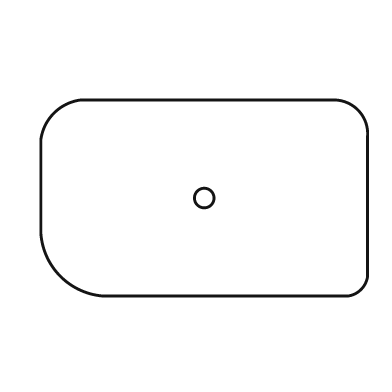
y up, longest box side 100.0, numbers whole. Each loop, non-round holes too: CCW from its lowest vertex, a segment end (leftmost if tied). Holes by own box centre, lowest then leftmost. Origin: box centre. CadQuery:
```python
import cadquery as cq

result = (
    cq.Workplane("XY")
    .moveTo(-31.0, -30.0)
    .lineTo(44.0, -30.0)
    .threePointArc((48.0, -28.0), (50.0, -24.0))
    .lineTo(50.0, 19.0)
    .threePointArc((47.0, 27.0), (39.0, 30.0))
    .lineTo(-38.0, 30.0)
    .threePointArc((-46.0, 26.0), (-50.0, 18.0))
    .lineTo(-50.0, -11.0)
    .threePointArc((-44.0, -24.0), (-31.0, -30.0))
    .close()
    .moveTo(0.0, 0.0)
    .circle(3.0)
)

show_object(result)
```